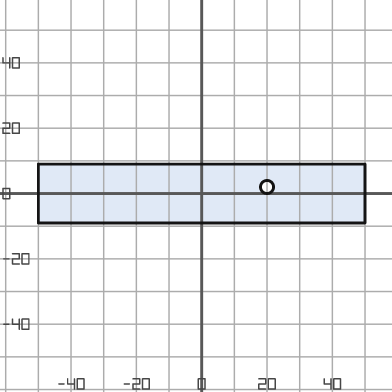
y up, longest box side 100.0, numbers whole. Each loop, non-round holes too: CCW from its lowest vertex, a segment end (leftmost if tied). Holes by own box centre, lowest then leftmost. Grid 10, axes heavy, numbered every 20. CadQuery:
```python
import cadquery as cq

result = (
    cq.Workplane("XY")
    .moveTo(-50.0, -9.0)
    .lineTo(50.0, -9.0)
    .lineTo(50.0, 9.0)
    .lineTo(-50.0, 9.0)
    .close()
    .moveTo(20.0, 2.0)
    .circle(2.0)
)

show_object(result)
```